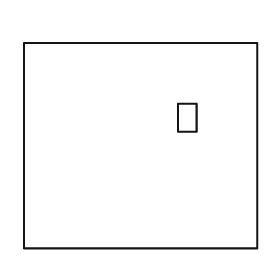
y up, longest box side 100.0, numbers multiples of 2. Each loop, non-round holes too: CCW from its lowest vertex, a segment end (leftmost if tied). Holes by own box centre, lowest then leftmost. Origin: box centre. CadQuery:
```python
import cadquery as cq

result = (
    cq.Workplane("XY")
    .moveTo(-50.0, -44.0)
    .lineTo(50.0, -44.0)
    .lineTo(50.0, 44.0)
    .lineTo(-50.0, 44.0)
    .close()
    .moveTo(16.0, 6.0)
    .lineTo(24.0, 6.0)
    .lineTo(24.0, 18.0)
    .lineTo(16.0, 18.0)
    .close()
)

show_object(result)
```